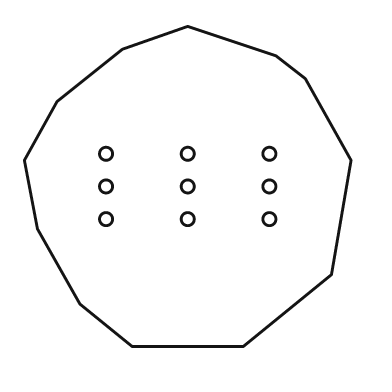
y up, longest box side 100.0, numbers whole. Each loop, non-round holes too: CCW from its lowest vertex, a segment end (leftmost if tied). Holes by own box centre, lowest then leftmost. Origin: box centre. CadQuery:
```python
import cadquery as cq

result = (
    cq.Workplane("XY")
    .moveTo(-17.0, -49.0)
    .lineTo(17.0, -49.0)
    .lineTo(44.0, -27.0)
    .lineTo(50.0, 8.0)
    .lineTo(36.0, 33.0)
    .lineTo(27.0, 40.0)
    .lineTo(0.0, 49.0)
    .lineTo(-20.0, 42.0)
    .lineTo(-40.0, 26.0)
    .lineTo(-50.0, 8.0)
    .lineTo(-46.0, -13.0)
    .lineTo(-33.0, -36.0)
    .close()
    .moveTo(-25.0, -10.0)
    .circle(2.0)
    .moveTo(0.0, -10.0)
    .circle(2.0)
    .moveTo(25.0, -10.0)
    .circle(2.0)
    .moveTo(-25.0, 0.0)
    .circle(2.0)
    .moveTo(0.0, 0.0)
    .circle(2.0)
    .moveTo(25.0, 0.0)
    .circle(2.0)
    .moveTo(-25.0, 10.0)
    .circle(2.0)
    .moveTo(0.0, 10.0)
    .circle(2.0)
    .moveTo(25.0, 10.0)
    .circle(2.0)
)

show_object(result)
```